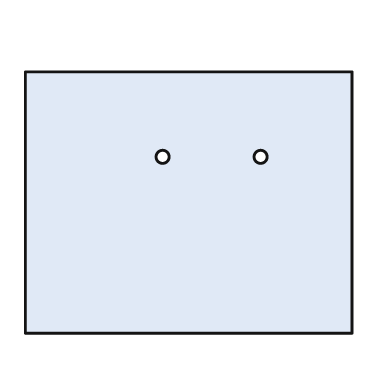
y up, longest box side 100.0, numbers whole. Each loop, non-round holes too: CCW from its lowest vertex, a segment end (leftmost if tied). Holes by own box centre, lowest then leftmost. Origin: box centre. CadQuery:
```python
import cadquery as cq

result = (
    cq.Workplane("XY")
    .moveTo(-50.0, -40.0)
    .lineTo(50.0, -40.0)
    .lineTo(50.0, 40.0)
    .lineTo(-50.0, 40.0)
    .close()
    .moveTo(-8.0, 14.0)
    .circle(2.0)
    .moveTo(22.0, 14.0)
    .circle(2.0)
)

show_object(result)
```